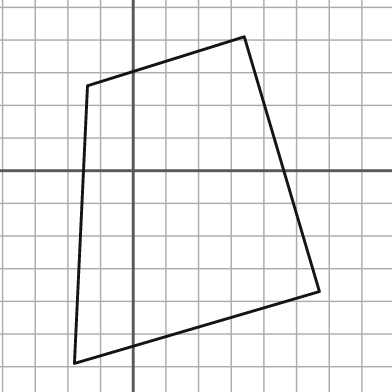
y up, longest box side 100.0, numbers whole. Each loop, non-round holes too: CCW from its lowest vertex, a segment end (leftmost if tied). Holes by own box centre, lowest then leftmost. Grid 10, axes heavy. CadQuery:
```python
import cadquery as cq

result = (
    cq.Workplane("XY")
    .moveTo(-18.0, -59.0)
    .lineTo(57.0, -37.0)
    .lineTo(34.0, 41.0)
    .lineTo(-14.0, 26.0)
    .close()
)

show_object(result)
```